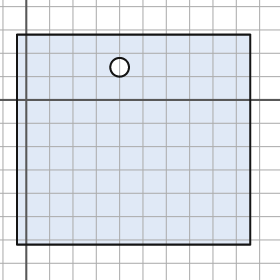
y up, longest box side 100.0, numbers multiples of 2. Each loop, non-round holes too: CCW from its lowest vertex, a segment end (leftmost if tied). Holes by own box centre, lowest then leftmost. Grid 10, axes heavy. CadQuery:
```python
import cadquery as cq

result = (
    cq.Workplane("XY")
    .moveTo(-4.0, -62.0)
    .lineTo(96.0, -62.0)
    .lineTo(96.0, 28.0)
    .lineTo(-4.0, 28.0)
    .close()
    .moveTo(40.0, 14.0)
    .circle(4.0)
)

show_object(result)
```